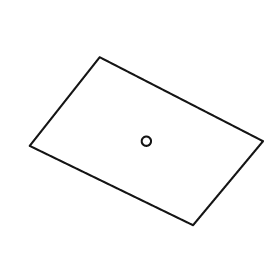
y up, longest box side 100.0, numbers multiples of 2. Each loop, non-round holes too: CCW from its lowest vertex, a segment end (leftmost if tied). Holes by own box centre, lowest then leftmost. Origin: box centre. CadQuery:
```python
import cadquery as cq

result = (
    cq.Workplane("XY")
    .moveTo(20.0, -36.0)
    .lineTo(50.0, 0.0)
    .lineTo(-20.0, 36.0)
    .lineTo(-50.0, -2.0)
    .close()
    .moveTo(0.0, 0.0)
    .circle(2.0)
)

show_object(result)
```